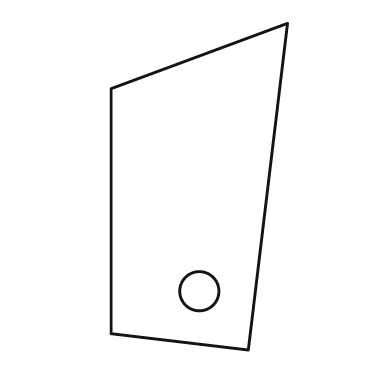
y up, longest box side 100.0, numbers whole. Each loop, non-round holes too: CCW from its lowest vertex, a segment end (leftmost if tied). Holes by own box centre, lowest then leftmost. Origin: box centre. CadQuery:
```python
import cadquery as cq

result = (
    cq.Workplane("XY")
    .moveTo(15.0, -50.0)
    .lineTo(27.0, 50.0)
    .lineTo(-27.0, 30.0)
    .lineTo(-27.0, -45.0)
    .close()
    .moveTo(0.0, -32.0)
    .circle(6.0)
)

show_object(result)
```